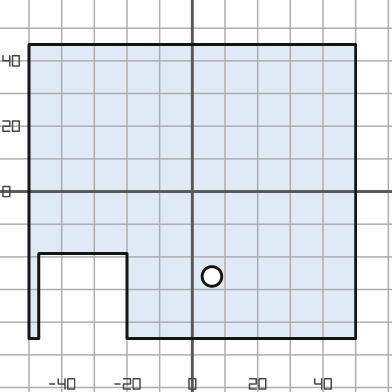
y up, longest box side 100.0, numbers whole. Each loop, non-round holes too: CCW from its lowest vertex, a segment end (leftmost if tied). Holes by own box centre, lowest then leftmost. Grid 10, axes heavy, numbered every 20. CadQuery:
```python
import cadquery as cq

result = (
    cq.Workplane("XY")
    .moveTo(-50.0, -45.0)
    .lineTo(-47.0, -45.0)
    .lineTo(-47.0, -19.0)
    .lineTo(-20.0, -19.0)
    .lineTo(-20.0, -45.0)
    .lineTo(50.0, -45.0)
    .lineTo(50.0, 45.0)
    .lineTo(-50.0, 45.0)
    .close()
    .moveTo(6.0, -26.0)
    .circle(3.0)
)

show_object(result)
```